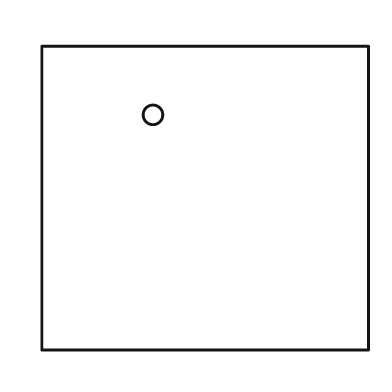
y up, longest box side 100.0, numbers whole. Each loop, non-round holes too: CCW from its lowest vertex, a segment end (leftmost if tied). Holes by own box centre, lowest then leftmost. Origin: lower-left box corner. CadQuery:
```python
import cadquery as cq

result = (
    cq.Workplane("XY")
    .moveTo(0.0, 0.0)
    .lineTo(100.0, 0.0)
    .lineTo(100.0, 93.0)
    .lineTo(0.0, 93.0)
    .close()
    .moveTo(34.0, 72.0)
    .circle(3.0)
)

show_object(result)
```